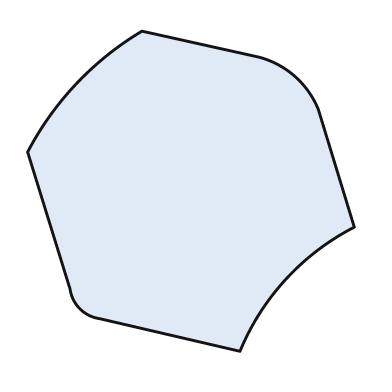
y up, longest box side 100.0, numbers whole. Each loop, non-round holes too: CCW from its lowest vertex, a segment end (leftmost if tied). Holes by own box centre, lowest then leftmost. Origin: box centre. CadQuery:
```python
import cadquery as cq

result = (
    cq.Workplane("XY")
    .moveTo(15.0, -49.0)
    .threePointArc((29.0, -27.0), (50.0, -11.0))
    .lineTo(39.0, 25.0)
    .threePointArc((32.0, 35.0), (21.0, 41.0))
    .lineTo(-15.0, 49.0)
    .threePointArc((-35.0, 33.0), (-50.0, 12.0))
    .lineTo(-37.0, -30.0)
    .threePointArc((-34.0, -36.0), (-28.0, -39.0))
    .close()
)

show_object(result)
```